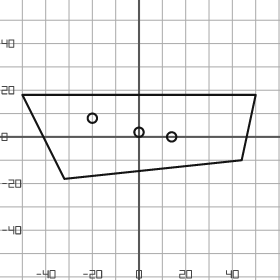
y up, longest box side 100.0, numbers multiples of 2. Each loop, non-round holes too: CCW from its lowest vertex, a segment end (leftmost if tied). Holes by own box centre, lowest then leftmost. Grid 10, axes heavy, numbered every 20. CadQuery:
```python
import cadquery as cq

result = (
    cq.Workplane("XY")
    .moveTo(-32.0, -18.0)
    .lineTo(44.0, -10.0)
    .lineTo(50.0, 18.0)
    .lineTo(-50.0, 18.0)
    .close()
    .moveTo(14.0, 0.0)
    .circle(2.0)
    .moveTo(0.0, 2.0)
    .circle(2.0)
    .moveTo(-20.0, 8.0)
    .circle(2.0)
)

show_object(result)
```